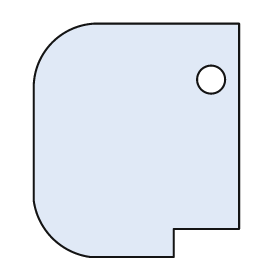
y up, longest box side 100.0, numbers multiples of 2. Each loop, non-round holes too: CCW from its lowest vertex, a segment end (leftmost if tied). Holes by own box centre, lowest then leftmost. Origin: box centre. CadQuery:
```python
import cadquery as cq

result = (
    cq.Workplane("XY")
    .moveTo(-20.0, -50.0)
    .lineTo(16.0, -50.0)
    .lineTo(16.0, -38.0)
    .lineTo(44.0, -38.0)
    .lineTo(44.0, 50.0)
    .lineTo(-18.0, 50.0)
    .threePointArc((-36.0, 42.0), (-44.0, 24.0))
    .lineTo(-44.0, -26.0)
    .threePointArc((-36.0, -42.0), (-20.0, -50.0))
    .close()
    .moveTo(32.0, 26.0)
    .circle(6.0)
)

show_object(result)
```